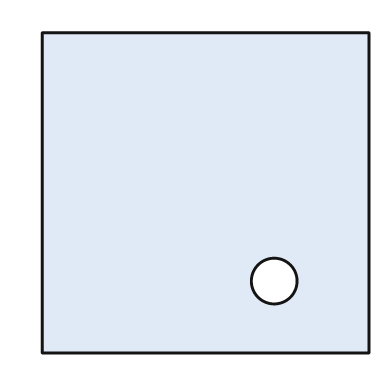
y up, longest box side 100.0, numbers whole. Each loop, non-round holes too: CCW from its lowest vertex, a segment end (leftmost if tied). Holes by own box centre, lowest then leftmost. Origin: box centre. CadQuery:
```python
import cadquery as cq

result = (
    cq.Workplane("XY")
    .moveTo(-50.0, -49.0)
    .lineTo(50.0, -49.0)
    .lineTo(50.0, 49.0)
    .lineTo(-50.0, 49.0)
    .close()
    .moveTo(21.0, -27.0)
    .circle(7.0)
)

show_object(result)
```